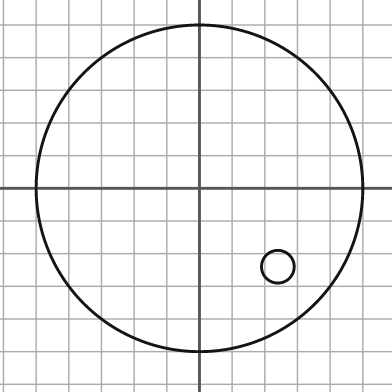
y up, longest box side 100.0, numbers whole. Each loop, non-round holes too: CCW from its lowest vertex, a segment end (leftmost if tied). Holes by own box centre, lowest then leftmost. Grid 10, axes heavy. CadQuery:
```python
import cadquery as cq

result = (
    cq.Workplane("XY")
    .moveTo(0.0, 0.0)
    .circle(50.0)
    .moveTo(24.0, -24.0)
    .circle(5.0)
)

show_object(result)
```